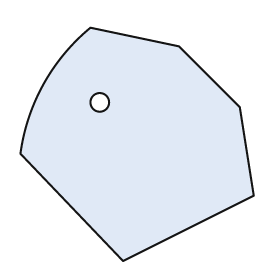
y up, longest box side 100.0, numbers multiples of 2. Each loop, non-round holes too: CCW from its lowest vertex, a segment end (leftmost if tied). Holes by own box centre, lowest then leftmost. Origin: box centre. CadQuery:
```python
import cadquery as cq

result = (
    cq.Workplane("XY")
    .moveTo(-6.0, -50.0)
    .lineTo(50.0, -22.0)
    .lineTo(44.0, 16.0)
    .lineTo(18.0, 42.0)
    .lineTo(-20.0, 50.0)
    .threePointArc((-40.0, 26.0), (-50.0, -4.0))
    .close()
    .moveTo(-16.0, 18.0)
    .circle(4.0)
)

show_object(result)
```